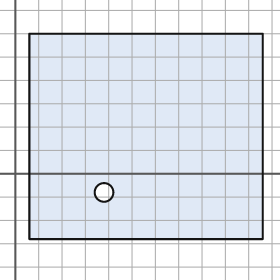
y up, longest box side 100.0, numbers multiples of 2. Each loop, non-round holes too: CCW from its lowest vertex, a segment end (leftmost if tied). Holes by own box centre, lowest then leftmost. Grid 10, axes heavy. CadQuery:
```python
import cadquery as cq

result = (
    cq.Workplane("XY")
    .moveTo(6.0, -28.0)
    .lineTo(106.0, -28.0)
    .lineTo(106.0, 60.0)
    .lineTo(6.0, 60.0)
    .close()
    .moveTo(38.0, -8.0)
    .circle(4.0)
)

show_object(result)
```